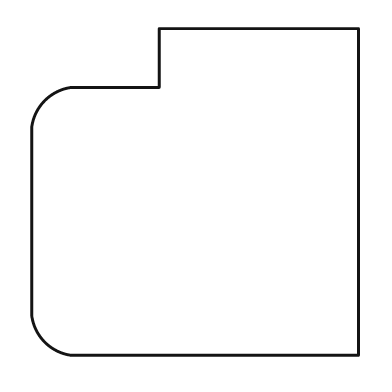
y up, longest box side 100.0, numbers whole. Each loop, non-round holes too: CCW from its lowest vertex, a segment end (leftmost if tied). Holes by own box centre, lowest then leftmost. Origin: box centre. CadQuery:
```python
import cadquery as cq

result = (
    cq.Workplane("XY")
    .moveTo(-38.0, -50.0)
    .lineTo(50.0, -50.0)
    .lineTo(50.0, 50.0)
    .lineTo(-11.0, 50.0)
    .lineTo(-11.0, 32.0)
    .lineTo(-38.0, 32.0)
    .threePointArc((-46.0, 28.0), (-50.0, 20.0))
    .lineTo(-50.0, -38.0)
    .threePointArc((-46.0, -46.0), (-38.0, -50.0))
    .close()
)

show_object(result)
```